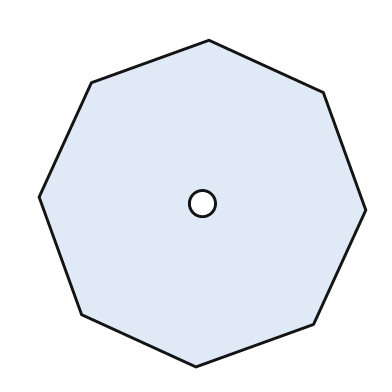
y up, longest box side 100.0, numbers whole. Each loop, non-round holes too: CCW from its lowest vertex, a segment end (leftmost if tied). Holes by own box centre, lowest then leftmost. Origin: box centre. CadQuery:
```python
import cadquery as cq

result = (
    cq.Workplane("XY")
    .moveTo(-2.0, -50.0)
    .lineTo(34.0, -37.0)
    .lineTo(50.0, -2.0)
    .lineTo(37.0, 34.0)
    .lineTo(2.0, 50.0)
    .lineTo(-34.0, 37.0)
    .lineTo(-50.0, 2.0)
    .lineTo(-37.0, -34.0)
    .close()
    .moveTo(0.0, 0.0)
    .circle(4.0)
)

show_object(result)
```